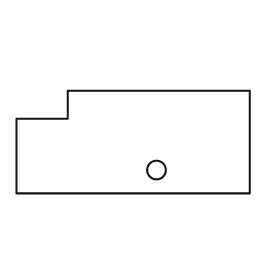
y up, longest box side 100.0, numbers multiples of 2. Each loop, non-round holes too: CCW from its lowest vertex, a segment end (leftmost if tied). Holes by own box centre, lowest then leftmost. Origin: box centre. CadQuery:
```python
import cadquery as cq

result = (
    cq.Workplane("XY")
    .moveTo(-50.0, -22.0)
    .lineTo(50.0, -22.0)
    .lineTo(50.0, 22.0)
    .lineTo(-28.0, 22.0)
    .lineTo(-28.0, 10.0)
    .lineTo(-50.0, 10.0)
    .close()
    .moveTo(10.0, -12.0)
    .circle(4.0)
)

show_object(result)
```